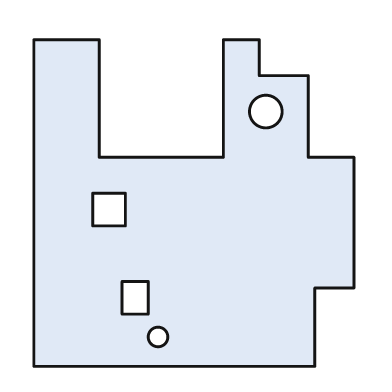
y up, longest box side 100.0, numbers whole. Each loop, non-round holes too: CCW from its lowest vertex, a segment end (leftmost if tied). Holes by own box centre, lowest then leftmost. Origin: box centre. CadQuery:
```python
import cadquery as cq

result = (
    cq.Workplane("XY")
    .moveTo(-49.0, -50.0)
    .lineTo(37.0, -50.0)
    .lineTo(37.0, -26.0)
    .lineTo(49.0, -26.0)
    .lineTo(49.0, 14.0)
    .lineTo(35.0, 14.0)
    .lineTo(35.0, 39.0)
    .lineTo(20.0, 39.0)
    .lineTo(20.0, 50.0)
    .lineTo(9.0, 50.0)
    .lineTo(9.0, 14.0)
    .lineTo(-29.0, 14.0)
    .lineTo(-29.0, 50.0)
    .lineTo(-49.0, 50.0)
    .close()
    .moveTo(-11.0, -41.0)
    .circle(3.0)
    .moveTo(-22.0, -34.0)
    .lineTo(-14.0, -34.0)
    .lineTo(-14.0, -24.0)
    .lineTo(-22.0, -24.0)
    .close()
    .moveTo(-31.0, -7.0)
    .lineTo(-21.0, -7.0)
    .lineTo(-21.0, 3.0)
    .lineTo(-31.0, 3.0)
    .close()
    .moveTo(22.0, 28.0)
    .circle(5.0)
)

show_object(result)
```